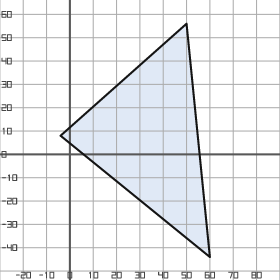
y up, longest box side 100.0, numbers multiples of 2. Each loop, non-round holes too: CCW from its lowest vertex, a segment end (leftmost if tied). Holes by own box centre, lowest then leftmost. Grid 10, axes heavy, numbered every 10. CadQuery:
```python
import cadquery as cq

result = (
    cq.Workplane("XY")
    .moveTo(60.0, -44.0)
    .lineTo(50.0, 56.0)
    .lineTo(-4.0, 8.0)
    .close()
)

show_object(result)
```